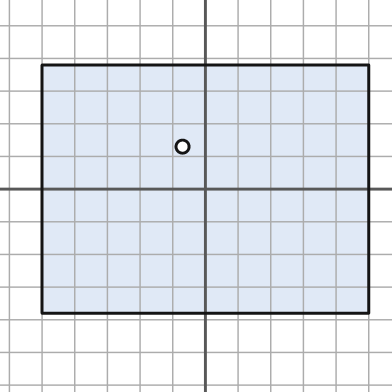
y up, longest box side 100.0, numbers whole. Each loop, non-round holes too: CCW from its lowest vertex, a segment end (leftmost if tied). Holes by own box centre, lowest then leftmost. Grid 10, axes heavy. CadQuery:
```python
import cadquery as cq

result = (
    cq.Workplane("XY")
    .moveTo(-50.0, -38.0)
    .lineTo(50.0, -38.0)
    .lineTo(50.0, 38.0)
    .lineTo(-50.0, 38.0)
    .close()
    .moveTo(-7.0, 13.0)
    .circle(2.0)
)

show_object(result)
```